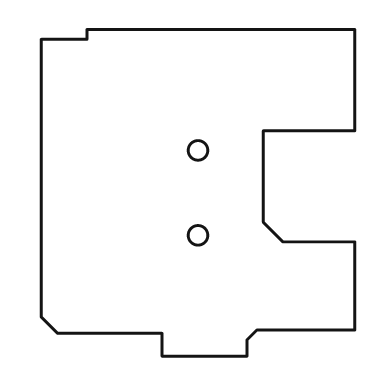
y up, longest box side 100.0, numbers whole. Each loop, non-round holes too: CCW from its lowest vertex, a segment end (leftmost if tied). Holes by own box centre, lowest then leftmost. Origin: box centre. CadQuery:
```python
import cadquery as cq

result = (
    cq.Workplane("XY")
    .moveTo(-11.0, -50.0)
    .lineTo(15.0, -50.0)
    .lineTo(15.0, -45.0)
    .lineTo(18.0, -42.0)
    .lineTo(48.0, -42.0)
    .lineTo(48.0, -15.0)
    .lineTo(26.0, -15.0)
    .lineTo(20.0, -9.0)
    .lineTo(20.0, 19.0)
    .lineTo(48.0, 19.0)
    .lineTo(48.0, 50.0)
    .lineTo(-34.0, 50.0)
    .lineTo(-34.0, 47.0)
    .lineTo(-48.0, 47.0)
    .lineTo(-48.0, -38.0)
    .lineTo(-43.0, -43.0)
    .lineTo(-11.0, -43.0)
    .close()
    .moveTo(0.0, -13.0)
    .circle(3.0)
    .moveTo(0.0, 13.0)
    .circle(3.0)
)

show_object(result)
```